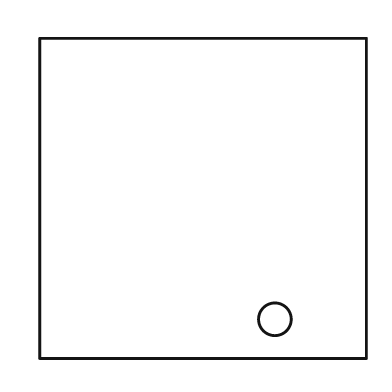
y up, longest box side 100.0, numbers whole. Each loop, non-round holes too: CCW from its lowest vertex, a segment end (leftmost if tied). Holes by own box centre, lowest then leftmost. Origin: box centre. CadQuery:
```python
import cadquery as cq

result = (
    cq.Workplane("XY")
    .moveTo(-50.0, -49.0)
    .lineTo(50.0, -49.0)
    .lineTo(50.0, 49.0)
    .lineTo(-50.0, 49.0)
    .close()
    .moveTo(22.0, -37.0)
    .circle(5.0)
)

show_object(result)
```